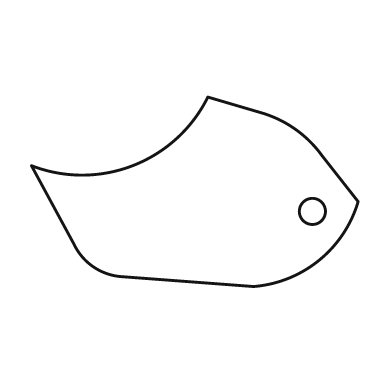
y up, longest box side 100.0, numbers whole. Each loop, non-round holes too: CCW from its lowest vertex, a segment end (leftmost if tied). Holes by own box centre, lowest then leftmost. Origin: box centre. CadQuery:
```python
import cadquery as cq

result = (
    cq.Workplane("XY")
    .moveTo(18.0, -29.0)
    .threePointArc((38.0, -21.0), (50.0, -3.0))
    .lineTo(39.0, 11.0)
    .threePointArc((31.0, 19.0), (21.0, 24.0))
    .lineTo(4.0, 29.0)
    .threePointArc((-19.0, 8.0), (-50.0, 8.0))
    .lineTo(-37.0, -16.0)
    .threePointArc((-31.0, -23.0), (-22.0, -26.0))
    .close()
    .moveTo(36.0, -6.0)
    .circle(4.0)
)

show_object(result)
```